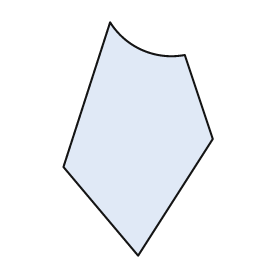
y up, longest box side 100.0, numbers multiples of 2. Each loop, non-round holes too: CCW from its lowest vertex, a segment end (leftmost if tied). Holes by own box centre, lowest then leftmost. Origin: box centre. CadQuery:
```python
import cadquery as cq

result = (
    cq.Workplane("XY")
    .moveTo(0.0, -50.0)
    .lineTo(32.0, 0.0)
    .lineTo(20.0, 36.0)
    .threePointArc((2.0, 38.0), (-12.0, 50.0))
    .lineTo(-32.0, -12.0)
    .close()
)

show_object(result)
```